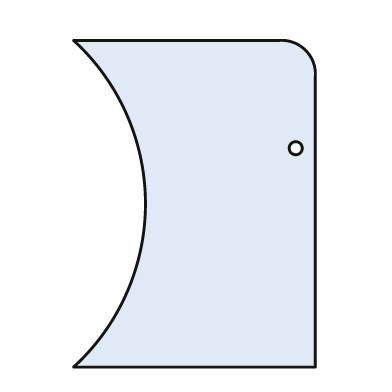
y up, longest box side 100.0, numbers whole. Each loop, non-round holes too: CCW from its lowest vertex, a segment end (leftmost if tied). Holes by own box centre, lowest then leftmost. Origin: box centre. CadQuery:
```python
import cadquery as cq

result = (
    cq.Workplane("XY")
    .moveTo(-37.0, -50.0)
    .lineTo(37.0, -50.0)
    .lineTo(37.0, 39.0)
    .threePointArc((34.0, 47.0), (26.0, 50.0))
    .lineTo(-37.0, 50.0)
    .threePointArc((-15.0, 0.0), (-37.0, -50.0))
    .close()
    .moveTo(31.0, 17.0)
    .circle(2.0)
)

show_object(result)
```